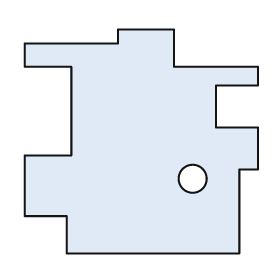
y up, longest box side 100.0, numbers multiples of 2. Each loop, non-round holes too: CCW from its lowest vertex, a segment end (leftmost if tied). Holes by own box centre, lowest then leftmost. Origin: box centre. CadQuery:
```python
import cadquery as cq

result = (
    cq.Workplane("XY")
    .moveTo(-32.0, -48.0)
    .lineTo(42.0, -48.0)
    .lineTo(42.0, -12.0)
    .lineTo(50.0, -12.0)
    .lineTo(50.0, 6.0)
    .lineTo(32.0, 6.0)
    .lineTo(32.0, 24.0)
    .lineTo(50.0, 24.0)
    .lineTo(50.0, 32.0)
    .lineTo(14.0, 32.0)
    .lineTo(14.0, 48.0)
    .lineTo(-10.0, 48.0)
    .lineTo(-10.0, 42.0)
    .lineTo(-50.0, 42.0)
    .lineTo(-50.0, 32.0)
    .lineTo(-30.0, 32.0)
    .lineTo(-30.0, -6.0)
    .lineTo(-50.0, -6.0)
    .lineTo(-50.0, -32.0)
    .lineTo(-32.0, -32.0)
    .close()
    .moveTo(22.0, -16.0)
    .circle(6.0)
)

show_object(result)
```